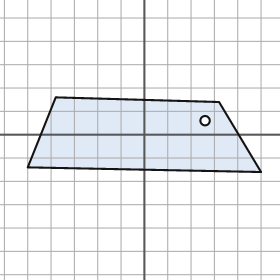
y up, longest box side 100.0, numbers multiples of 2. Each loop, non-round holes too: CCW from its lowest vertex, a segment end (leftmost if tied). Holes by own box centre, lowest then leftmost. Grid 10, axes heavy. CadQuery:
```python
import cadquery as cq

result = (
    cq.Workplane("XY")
    .moveTo(50.0, -16.0)
    .lineTo(32.0, 14.0)
    .lineTo(-38.0, 16.0)
    .lineTo(-50.0, -14.0)
    .close()
    .moveTo(26.0, 6.0)
    .circle(2.0)
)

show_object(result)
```